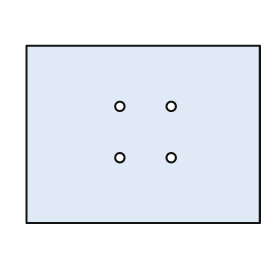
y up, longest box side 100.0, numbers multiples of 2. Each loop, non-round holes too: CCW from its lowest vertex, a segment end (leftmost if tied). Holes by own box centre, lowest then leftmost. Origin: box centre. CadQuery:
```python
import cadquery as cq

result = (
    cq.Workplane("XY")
    .moveTo(-50.0, -38.0)
    .lineTo(50.0, -38.0)
    .lineTo(50.0, 38.0)
    .lineTo(-50.0, 38.0)
    .close()
    .moveTo(-10.0, -10.0)
    .circle(2.0)
    .moveTo(12.0, -10.0)
    .circle(2.0)
    .moveTo(-10.0, 12.0)
    .circle(2.0)
    .moveTo(12.0, 12.0)
    .circle(2.0)
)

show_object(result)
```